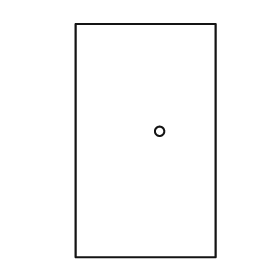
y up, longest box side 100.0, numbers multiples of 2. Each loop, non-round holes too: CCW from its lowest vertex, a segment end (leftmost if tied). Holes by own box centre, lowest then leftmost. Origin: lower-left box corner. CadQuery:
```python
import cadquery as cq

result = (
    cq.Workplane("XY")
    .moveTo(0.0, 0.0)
    .lineTo(60.0, 0.0)
    .lineTo(60.0, 100.0)
    .lineTo(0.0, 100.0)
    .close()
    .moveTo(36.0, 54.0)
    .circle(2.0)
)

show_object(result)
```